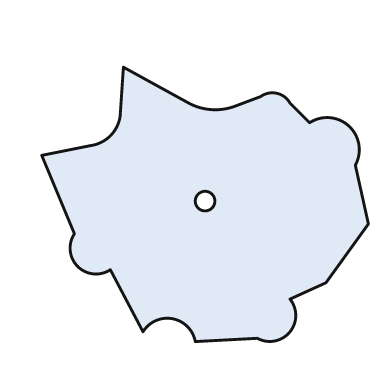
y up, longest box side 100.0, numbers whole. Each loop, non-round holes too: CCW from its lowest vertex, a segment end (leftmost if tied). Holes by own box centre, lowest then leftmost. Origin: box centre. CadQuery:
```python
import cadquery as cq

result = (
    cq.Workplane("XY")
    .moveTo(-3.0, -42.0)
    .lineTo(16.0, -41.0)
    .threePointArc((26.0, -39.0), (26.0, -29.0))
    .lineTo(37.0, -24.0)
    .lineTo(50.0, -6.0)
    .lineTo(46.0, 12.0)
    .threePointArc((44.0, 24.0), (32.0, 25.0))
    .lineTo(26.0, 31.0)
    .threePointArc((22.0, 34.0), (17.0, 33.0))
    .lineTo(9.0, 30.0)
    .threePointArc((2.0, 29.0), (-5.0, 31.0))
    .lineTo(-25.0, 42.0)
    .lineTo(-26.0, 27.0)
    .threePointArc((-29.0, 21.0), (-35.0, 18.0))
    .lineTo(-50.0, 15.0)
    .lineTo(-40.0, -9.0)
    .threePointArc((-39.0, -19.0), (-29.0, -20.0))
    .lineTo(-19.0, -39.0)
    .threePointArc((-10.0, -35.0), (-3.0, -42.0))
    .close()
    .moveTo(0.0, 1.0)
    .circle(3.0)
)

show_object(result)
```